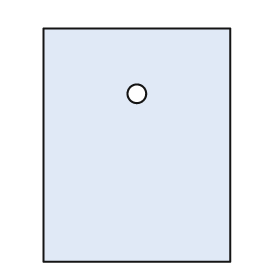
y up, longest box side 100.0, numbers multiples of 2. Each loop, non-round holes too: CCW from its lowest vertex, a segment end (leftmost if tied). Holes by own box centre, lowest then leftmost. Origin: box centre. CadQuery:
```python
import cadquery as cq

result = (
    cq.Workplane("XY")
    .moveTo(-40.0, -50.0)
    .lineTo(40.0, -50.0)
    .lineTo(40.0, 50.0)
    .lineTo(-40.0, 50.0)
    .close()
    .moveTo(0.0, 22.0)
    .circle(4.0)
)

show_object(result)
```